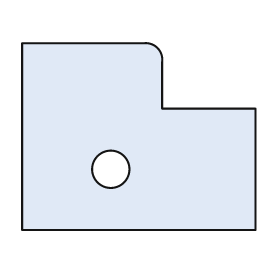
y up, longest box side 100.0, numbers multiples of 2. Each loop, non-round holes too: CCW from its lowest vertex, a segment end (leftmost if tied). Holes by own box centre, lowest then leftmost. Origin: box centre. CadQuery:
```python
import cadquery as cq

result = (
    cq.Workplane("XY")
    .moveTo(-50.0, -40.0)
    .lineTo(50.0, -40.0)
    .lineTo(50.0, 12.0)
    .lineTo(10.0, 12.0)
    .lineTo(10.0, 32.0)
    .threePointArc((8.0, 38.0), (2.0, 40.0))
    .lineTo(-50.0, 40.0)
    .close()
    .moveTo(-12.0, -14.0)
    .circle(8.0)
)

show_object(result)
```